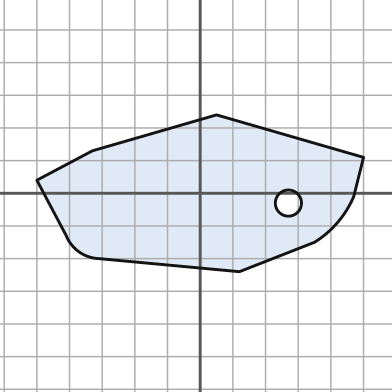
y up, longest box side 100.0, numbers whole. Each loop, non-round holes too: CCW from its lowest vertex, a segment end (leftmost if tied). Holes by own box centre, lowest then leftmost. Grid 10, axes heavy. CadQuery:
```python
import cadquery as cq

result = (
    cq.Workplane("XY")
    .moveTo(12.0, -24.0)
    .lineTo(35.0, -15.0)
    .threePointArc((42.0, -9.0), (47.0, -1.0))
    .lineTo(50.0, 11.0)
    .lineTo(5.0, 24.0)
    .lineTo(-33.0, 13.0)
    .lineTo(-50.0, 4.0)
    .lineTo(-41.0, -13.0)
    .threePointArc((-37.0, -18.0), (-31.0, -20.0))
    .close()
    .moveTo(27.0, -3.0)
    .circle(4.0)
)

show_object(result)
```